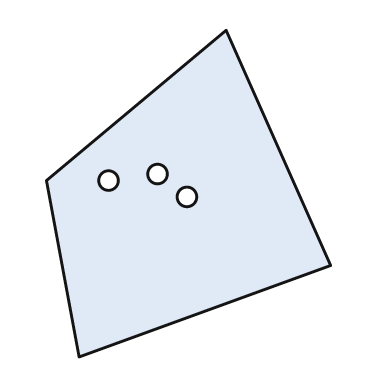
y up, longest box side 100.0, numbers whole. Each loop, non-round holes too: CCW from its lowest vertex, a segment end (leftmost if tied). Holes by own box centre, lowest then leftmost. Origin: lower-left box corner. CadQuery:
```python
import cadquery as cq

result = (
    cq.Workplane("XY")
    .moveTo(10.0, 0.0)
    .lineTo(87.0, 28.0)
    .lineTo(55.0, 100.0)
    .lineTo(0.0, 54.0)
    .close()
    .moveTo(43.0, 49.0)
    .circle(3.0)
    .moveTo(19.0, 54.0)
    .circle(3.0)
    .moveTo(34.0, 56.0)
    .circle(3.0)
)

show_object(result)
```